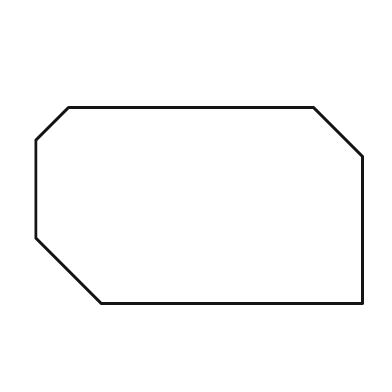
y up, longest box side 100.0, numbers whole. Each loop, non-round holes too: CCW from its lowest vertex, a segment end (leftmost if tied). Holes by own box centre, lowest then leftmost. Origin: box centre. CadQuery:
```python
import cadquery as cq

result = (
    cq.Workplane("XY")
    .moveTo(-30.0, -30.0)
    .lineTo(50.0, -30.0)
    .lineTo(50.0, 15.0)
    .lineTo(35.0, 30.0)
    .lineTo(-40.0, 30.0)
    .lineTo(-50.0, 20.0)
    .lineTo(-50.0, -10.0)
    .close()
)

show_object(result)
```